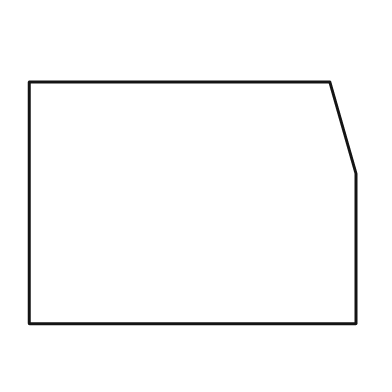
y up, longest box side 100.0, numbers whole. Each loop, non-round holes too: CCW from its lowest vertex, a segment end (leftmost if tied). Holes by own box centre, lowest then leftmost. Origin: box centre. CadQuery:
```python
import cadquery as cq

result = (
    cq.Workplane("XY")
    .moveTo(-50.0, -37.0)
    .lineTo(50.0, -37.0)
    .lineTo(50.0, 9.0)
    .lineTo(42.0, 37.0)
    .lineTo(-50.0, 37.0)
    .close()
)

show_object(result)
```